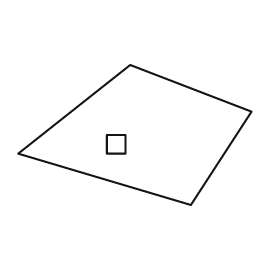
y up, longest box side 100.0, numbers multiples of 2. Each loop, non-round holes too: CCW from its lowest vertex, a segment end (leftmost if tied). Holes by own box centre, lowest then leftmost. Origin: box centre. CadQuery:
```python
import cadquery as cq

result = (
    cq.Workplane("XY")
    .moveTo(24.0, -30.0)
    .lineTo(50.0, 10.0)
    .lineTo(-2.0, 30.0)
    .lineTo(-50.0, -8.0)
    .close()
    .moveTo(-12.0, -8.0)
    .lineTo(-4.0, -8.0)
    .lineTo(-4.0, 0.0)
    .lineTo(-12.0, 0.0)
    .close()
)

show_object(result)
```